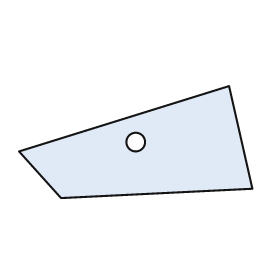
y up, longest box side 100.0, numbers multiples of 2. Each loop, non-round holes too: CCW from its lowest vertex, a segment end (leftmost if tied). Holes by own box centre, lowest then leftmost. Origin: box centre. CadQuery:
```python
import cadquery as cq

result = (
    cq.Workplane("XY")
    .moveTo(-32.0, -24.0)
    .lineTo(50.0, -20.0)
    .lineTo(40.0, 24.0)
    .lineTo(-50.0, -4.0)
    .close()
    .moveTo(0.0, 0.0)
    .circle(4.0)
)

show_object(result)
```